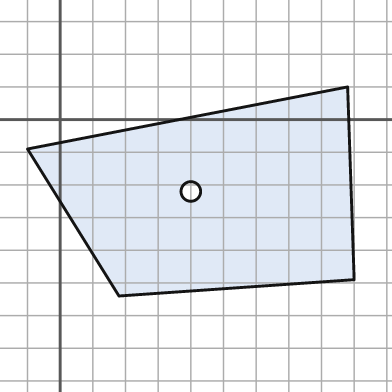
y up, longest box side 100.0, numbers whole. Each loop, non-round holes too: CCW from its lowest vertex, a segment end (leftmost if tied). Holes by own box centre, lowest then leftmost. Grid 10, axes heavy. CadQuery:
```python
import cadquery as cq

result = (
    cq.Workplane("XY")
    .moveTo(18.0, -54.0)
    .lineTo(90.0, -49.0)
    .lineTo(88.0, 10.0)
    .lineTo(-10.0, -9.0)
    .close()
    .moveTo(40.0, -22.0)
    .circle(3.0)
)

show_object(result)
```